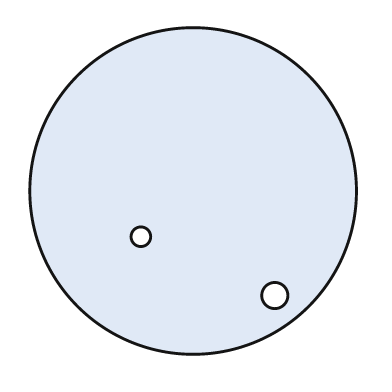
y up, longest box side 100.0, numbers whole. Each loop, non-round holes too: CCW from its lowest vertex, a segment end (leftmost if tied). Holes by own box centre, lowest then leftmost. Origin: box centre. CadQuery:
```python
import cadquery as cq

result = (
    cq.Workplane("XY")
    .moveTo(0.0, 0.0)
    .circle(50.0)
    .moveTo(25.0, -32.0)
    .circle(4.0)
    .moveTo(-16.0, -14.0)
    .circle(3.0)
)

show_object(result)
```